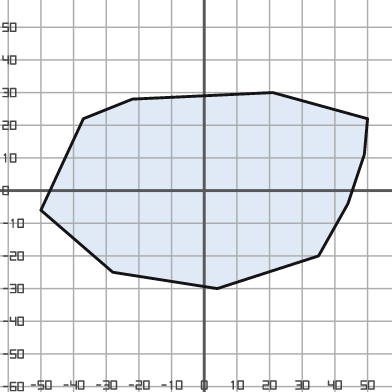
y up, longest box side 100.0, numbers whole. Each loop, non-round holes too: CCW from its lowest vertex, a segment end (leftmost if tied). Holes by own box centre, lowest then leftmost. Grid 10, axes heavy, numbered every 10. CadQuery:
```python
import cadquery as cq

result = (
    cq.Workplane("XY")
    .moveTo(4.0, -30.0)
    .lineTo(35.0, -20.0)
    .lineTo(44.0, -4.0)
    .lineTo(49.0, 11.0)
    .lineTo(50.0, 22.0)
    .lineTo(21.0, 30.0)
    .lineTo(-22.0, 28.0)
    .lineTo(-37.0, 22.0)
    .lineTo(-50.0, -6.0)
    .lineTo(-28.0, -25.0)
    .close()
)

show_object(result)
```